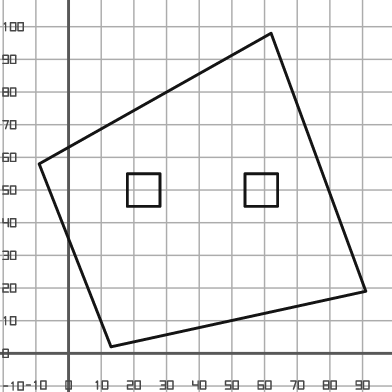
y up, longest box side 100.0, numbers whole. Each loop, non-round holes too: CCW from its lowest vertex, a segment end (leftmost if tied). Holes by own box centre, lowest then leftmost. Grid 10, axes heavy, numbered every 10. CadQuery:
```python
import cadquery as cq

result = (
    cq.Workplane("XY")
    .moveTo(13.0, 2.0)
    .lineTo(91.0, 19.0)
    .lineTo(62.0, 98.0)
    .lineTo(-9.0, 58.0)
    .close()
    .moveTo(18.0, 45.0)
    .lineTo(28.0, 45.0)
    .lineTo(28.0, 55.0)
    .lineTo(18.0, 55.0)
    .close()
    .moveTo(54.0, 45.0)
    .lineTo(64.0, 45.0)
    .lineTo(64.0, 55.0)
    .lineTo(54.0, 55.0)
    .close()
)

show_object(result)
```